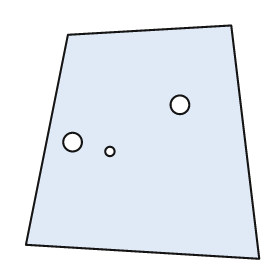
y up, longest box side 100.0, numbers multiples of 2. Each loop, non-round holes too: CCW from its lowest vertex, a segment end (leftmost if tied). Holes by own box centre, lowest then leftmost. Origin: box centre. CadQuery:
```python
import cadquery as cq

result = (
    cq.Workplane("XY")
    .moveTo(50.0, -50.0)
    .lineTo(38.0, 50.0)
    .lineTo(-32.0, 46.0)
    .lineTo(-50.0, -44.0)
    .close()
    .moveTo(-14.0, -4.0)
    .circle(2.0)
    .moveTo(-30.0, 0.0)
    .circle(4.0)
    .moveTo(16.0, 16.0)
    .circle(4.0)
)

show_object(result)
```